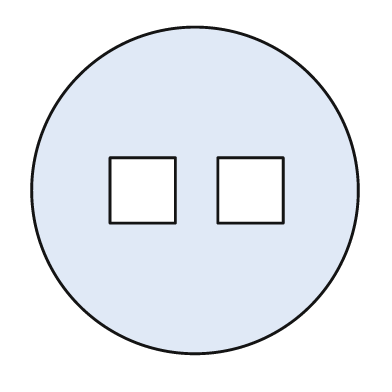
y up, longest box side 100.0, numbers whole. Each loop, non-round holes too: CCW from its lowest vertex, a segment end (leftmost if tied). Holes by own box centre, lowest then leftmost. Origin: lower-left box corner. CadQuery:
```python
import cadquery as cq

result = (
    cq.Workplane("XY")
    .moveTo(50.0, 50.0)
    .circle(50.0)
    .moveTo(24.0, 40.0)
    .lineTo(44.0, 40.0)
    .lineTo(44.0, 60.0)
    .lineTo(24.0, 60.0)
    .close()
    .moveTo(57.0, 40.0)
    .lineTo(77.0, 40.0)
    .lineTo(77.0, 60.0)
    .lineTo(57.0, 60.0)
    .close()
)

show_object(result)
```